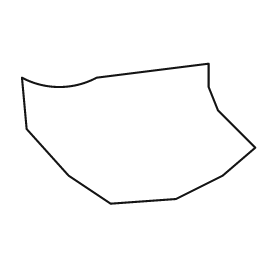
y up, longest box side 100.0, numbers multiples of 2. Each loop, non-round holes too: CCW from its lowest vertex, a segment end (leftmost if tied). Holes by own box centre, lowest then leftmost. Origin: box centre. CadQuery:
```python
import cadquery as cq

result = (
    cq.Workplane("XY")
    .moveTo(-12.0, -30.0)
    .lineTo(16.0, -28.0)
    .lineTo(36.0, -18.0)
    .lineTo(50.0, -6.0)
    .lineTo(34.0, 10.0)
    .lineTo(30.0, 20.0)
    .lineTo(30.0, 30.0)
    .lineTo(-18.0, 24.0)
    .threePointArc((-34.0, 20.0), (-50.0, 24.0))
    .lineTo(-48.0, 2.0)
    .lineTo(-30.0, -18.0)
    .close()
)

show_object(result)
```